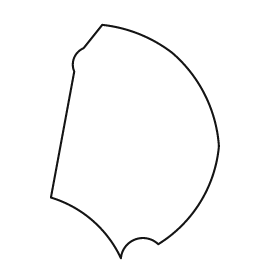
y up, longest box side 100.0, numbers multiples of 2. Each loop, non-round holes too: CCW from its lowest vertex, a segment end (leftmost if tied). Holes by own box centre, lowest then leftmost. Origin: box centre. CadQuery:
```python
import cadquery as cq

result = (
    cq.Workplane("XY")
    .moveTo(-6.0, -50.0)
    .threePointArc((0.0, -42.0), (10.0, -44.0))
    .threePointArc((28.0, -26.0), (36.0, -2.0))
    .threePointArc((30.0, 20.0), (16.0, 38.0))
    .threePointArc((2.0, 46.0), (-14.0, 50.0))
    .lineTo(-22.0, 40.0)
    .threePointArc((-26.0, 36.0), (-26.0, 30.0))
    .lineTo(-36.0, -24.0)
    .threePointArc((-18.0, -34.0), (-6.0, -50.0))
    .close()
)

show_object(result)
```